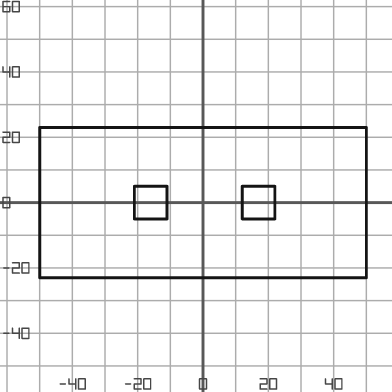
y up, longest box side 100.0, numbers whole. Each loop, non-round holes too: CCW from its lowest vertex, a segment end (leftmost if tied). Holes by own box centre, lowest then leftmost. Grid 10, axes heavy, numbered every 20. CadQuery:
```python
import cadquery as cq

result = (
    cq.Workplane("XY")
    .moveTo(-50.0, -23.0)
    .lineTo(50.0, -23.0)
    .lineTo(50.0, 23.0)
    .lineTo(-50.0, 23.0)
    .close()
    .moveTo(-21.0, -5.0)
    .lineTo(-11.0, -5.0)
    .lineTo(-11.0, 5.0)
    .lineTo(-21.0, 5.0)
    .close()
    .moveTo(12.0, -5.0)
    .lineTo(22.0, -5.0)
    .lineTo(22.0, 5.0)
    .lineTo(12.0, 5.0)
    .close()
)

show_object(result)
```